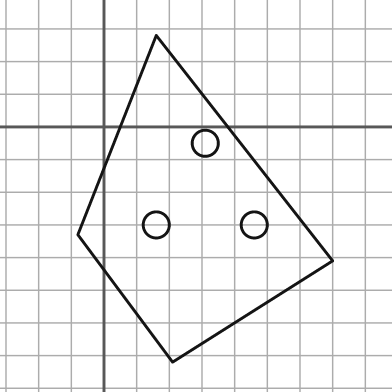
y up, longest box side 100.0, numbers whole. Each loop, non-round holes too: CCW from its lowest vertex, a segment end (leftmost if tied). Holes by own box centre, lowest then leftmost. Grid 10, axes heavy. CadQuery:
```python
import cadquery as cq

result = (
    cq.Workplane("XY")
    .moveTo(21.0, -72.0)
    .lineTo(70.0, -41.0)
    .lineTo(16.0, 28.0)
    .lineTo(-8.0, -33.0)
    .close()
    .moveTo(16.0, -30.0)
    .circle(4.0)
    .moveTo(46.0, -30.0)
    .circle(4.0)
    .moveTo(31.0, -5.0)
    .circle(4.0)
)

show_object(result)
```